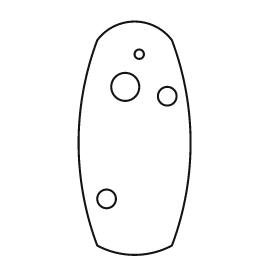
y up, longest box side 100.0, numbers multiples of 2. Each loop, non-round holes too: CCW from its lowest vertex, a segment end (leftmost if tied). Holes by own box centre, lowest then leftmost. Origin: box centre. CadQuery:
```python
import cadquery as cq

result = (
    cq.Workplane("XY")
    .moveTo(-16.0, -46.0)
    .threePointArc((0.0, -50.0), (16.0, -46.0))
    .threePointArc((24.0, -2.0), (16.0, 42.0))
    .threePointArc((0.0, 50.0), (-16.0, 42.0))
    .threePointArc((-24.0, -2.0), (-16.0, -46.0))
    .close()
    .moveTo(-12.0, -26.0)
    .circle(4.0)
    .moveTo(14.0, 18.0)
    .circle(4.0)
    .moveTo(-4.0, 22.0)
    .circle(6.0)
    .moveTo(2.0, 36.0)
    .circle(2.0)
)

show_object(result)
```